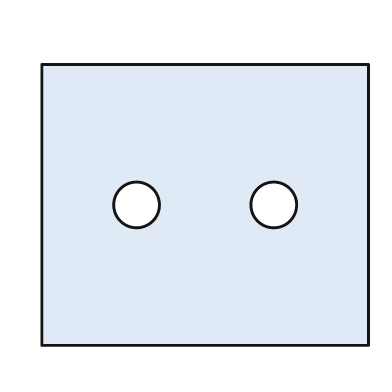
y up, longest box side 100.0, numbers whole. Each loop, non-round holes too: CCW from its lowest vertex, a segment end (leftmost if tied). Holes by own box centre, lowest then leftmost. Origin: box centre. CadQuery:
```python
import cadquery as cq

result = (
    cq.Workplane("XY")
    .moveTo(-50.0, -43.0)
    .lineTo(50.0, -43.0)
    .lineTo(50.0, 43.0)
    .lineTo(-50.0, 43.0)
    .close()
    .moveTo(-21.0, 0.0)
    .circle(7.0)
    .moveTo(21.0, 0.0)
    .circle(7.0)
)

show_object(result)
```